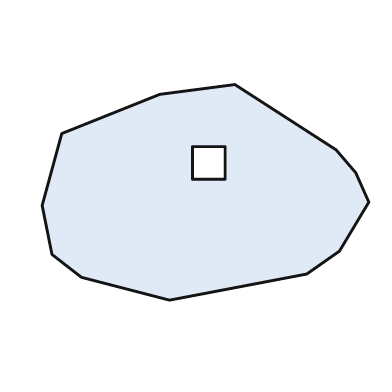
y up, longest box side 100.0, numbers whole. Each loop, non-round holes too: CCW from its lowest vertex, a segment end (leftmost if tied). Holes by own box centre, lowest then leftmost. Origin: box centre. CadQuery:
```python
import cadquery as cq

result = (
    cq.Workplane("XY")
    .moveTo(-11.0, -33.0)
    .lineTo(31.0, -25.0)
    .lineTo(41.0, -18.0)
    .lineTo(50.0, -3.0)
    .lineTo(46.0, 6.0)
    .lineTo(40.0, 13.0)
    .lineTo(9.0, 33.0)
    .lineTo(-14.0, 30.0)
    .lineTo(-44.0, 18.0)
    .lineTo(-50.0, -4.0)
    .lineTo(-47.0, -19.0)
    .lineTo(-38.0, -26.0)
    .close()
    .moveTo(-4.0, 4.0)
    .lineTo(6.0, 4.0)
    .lineTo(6.0, 14.0)
    .lineTo(-4.0, 14.0)
    .close()
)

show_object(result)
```